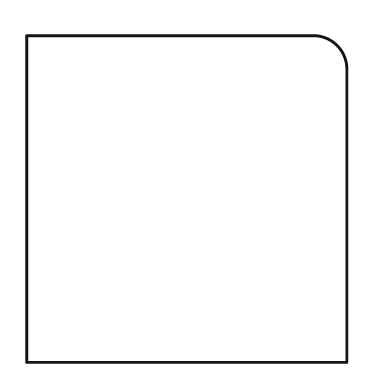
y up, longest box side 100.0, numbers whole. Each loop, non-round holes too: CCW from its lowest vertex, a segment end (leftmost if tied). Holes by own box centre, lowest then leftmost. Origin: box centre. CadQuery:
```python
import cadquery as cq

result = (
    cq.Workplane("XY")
    .moveTo(-49.0, -50.0)
    .lineTo(49.0, -50.0)
    .lineTo(49.0, 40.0)
    .threePointArc((46.0, 47.0), (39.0, 50.0))
    .lineTo(-49.0, 50.0)
    .close()
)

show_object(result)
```